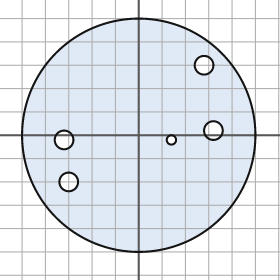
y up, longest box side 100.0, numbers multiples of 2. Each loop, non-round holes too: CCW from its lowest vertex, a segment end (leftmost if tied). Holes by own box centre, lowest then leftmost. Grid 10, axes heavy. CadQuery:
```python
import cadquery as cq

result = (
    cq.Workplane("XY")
    .moveTo(0.0, 0.0)
    .circle(50.0)
    .moveTo(-30.0, -20.0)
    .circle(4.0)
    .moveTo(-32.0, -2.0)
    .circle(4.0)
    .moveTo(14.0, -2.0)
    .circle(2.0)
    .moveTo(32.0, 2.0)
    .circle(4.0)
    .moveTo(28.0, 30.0)
    .circle(4.0)
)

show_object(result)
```